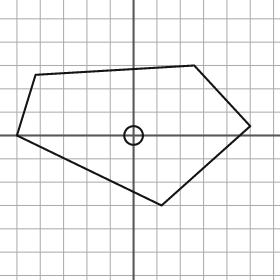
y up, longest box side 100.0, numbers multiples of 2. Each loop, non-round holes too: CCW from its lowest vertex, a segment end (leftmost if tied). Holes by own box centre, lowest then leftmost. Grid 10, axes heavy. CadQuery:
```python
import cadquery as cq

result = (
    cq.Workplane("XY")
    .moveTo(12.0, -30.0)
    .lineTo(50.0, 4.0)
    .lineTo(26.0, 30.0)
    .lineTo(-42.0, 26.0)
    .lineTo(-50.0, 0.0)
    .close()
    .moveTo(0.0, 0.0)
    .circle(4.0)
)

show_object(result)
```